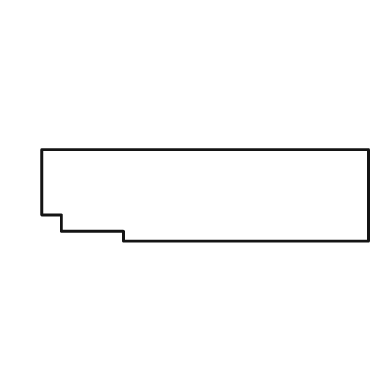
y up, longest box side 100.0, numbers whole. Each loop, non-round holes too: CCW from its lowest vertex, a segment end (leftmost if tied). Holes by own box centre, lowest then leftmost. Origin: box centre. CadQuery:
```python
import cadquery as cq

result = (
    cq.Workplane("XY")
    .moveTo(-25.0, -14.0)
    .lineTo(50.0, -14.0)
    .lineTo(50.0, 14.0)
    .lineTo(-50.0, 14.0)
    .lineTo(-50.0, -6.0)
    .lineTo(-44.0, -6.0)
    .lineTo(-44.0, -11.0)
    .lineTo(-25.0, -11.0)
    .close()
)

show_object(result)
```